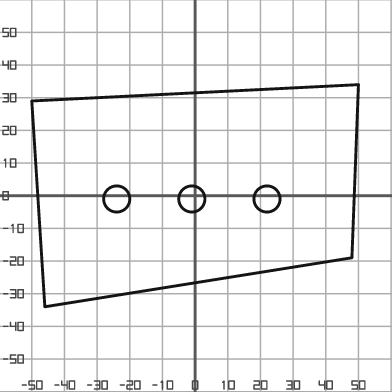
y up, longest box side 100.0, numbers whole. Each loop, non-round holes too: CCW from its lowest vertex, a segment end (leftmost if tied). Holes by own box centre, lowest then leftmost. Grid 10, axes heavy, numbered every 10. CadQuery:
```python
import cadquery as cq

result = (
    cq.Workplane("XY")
    .moveTo(-46.0, -34.0)
    .lineTo(48.0, -19.0)
    .lineTo(50.0, 34.0)
    .lineTo(-50.0, 29.0)
    .close()
    .moveTo(-24.0, -1.0)
    .circle(4.0)
    .moveTo(-1.0, -1.0)
    .circle(4.0)
    .moveTo(22.0, -1.0)
    .circle(4.0)
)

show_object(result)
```